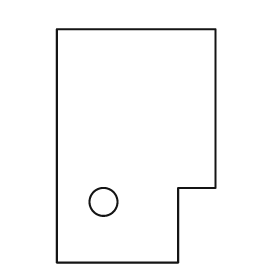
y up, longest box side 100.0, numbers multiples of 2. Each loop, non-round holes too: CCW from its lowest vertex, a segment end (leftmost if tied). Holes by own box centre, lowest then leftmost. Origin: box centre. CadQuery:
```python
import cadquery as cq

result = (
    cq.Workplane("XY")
    .moveTo(-34.0, -50.0)
    .lineTo(18.0, -50.0)
    .lineTo(18.0, -18.0)
    .lineTo(34.0, -18.0)
    .lineTo(34.0, 50.0)
    .lineTo(-34.0, 50.0)
    .close()
    .moveTo(-14.0, -24.0)
    .circle(6.0)
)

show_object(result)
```